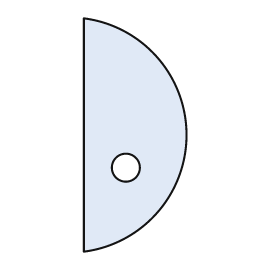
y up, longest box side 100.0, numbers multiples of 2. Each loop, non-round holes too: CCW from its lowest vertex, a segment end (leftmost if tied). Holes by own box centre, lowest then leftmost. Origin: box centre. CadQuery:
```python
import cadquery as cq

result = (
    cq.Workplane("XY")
    .moveTo(-22.0, -50.0)
    .threePointArc((22.0, 0.0), (-22.0, 50.0))
    .close()
    .moveTo(-4.0, -14.0)
    .circle(6.0)
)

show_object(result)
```